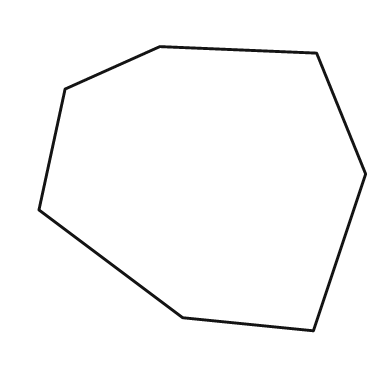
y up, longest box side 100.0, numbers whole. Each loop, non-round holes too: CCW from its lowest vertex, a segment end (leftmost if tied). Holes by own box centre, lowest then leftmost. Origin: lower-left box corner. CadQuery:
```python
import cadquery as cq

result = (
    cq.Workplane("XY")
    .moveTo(84.0, 0.0)
    .lineTo(100.0, 48.0)
    .lineTo(85.0, 85.0)
    .lineTo(37.0, 87.0)
    .lineTo(8.0, 74.0)
    .lineTo(0.0, 37.0)
    .lineTo(44.0, 4.0)
    .close()
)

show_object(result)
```